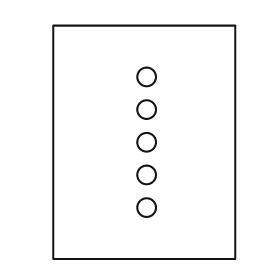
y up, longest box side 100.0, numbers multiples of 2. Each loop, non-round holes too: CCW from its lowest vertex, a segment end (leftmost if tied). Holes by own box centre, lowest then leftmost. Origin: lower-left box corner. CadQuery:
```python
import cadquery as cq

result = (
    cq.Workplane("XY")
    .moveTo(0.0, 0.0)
    .lineTo(78.0, 0.0)
    .lineTo(78.0, 100.0)
    .lineTo(0.0, 100.0)
    .close()
    .moveTo(40.0, 22.0)
    .circle(4.0)
    .moveTo(40.0, 36.0)
    .circle(4.0)
    .moveTo(40.0, 50.0)
    .circle(4.0)
    .moveTo(40.0, 64.0)
    .circle(4.0)
    .moveTo(40.0, 78.0)
    .circle(4.0)
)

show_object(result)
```